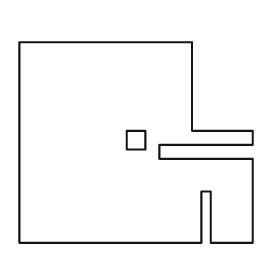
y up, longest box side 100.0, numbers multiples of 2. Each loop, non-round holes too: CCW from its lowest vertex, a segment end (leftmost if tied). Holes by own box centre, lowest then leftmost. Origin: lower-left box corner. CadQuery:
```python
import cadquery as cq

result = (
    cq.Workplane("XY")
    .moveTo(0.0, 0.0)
    .lineTo(78.0, 0.0)
    .lineTo(78.0, 22.0)
    .lineTo(82.0, 22.0)
    .lineTo(82.0, 0.0)
    .lineTo(100.0, 0.0)
    .lineTo(100.0, 36.0)
    .lineTo(60.0, 36.0)
    .lineTo(60.0, 42.0)
    .lineTo(100.0, 42.0)
    .lineTo(100.0, 48.0)
    .lineTo(74.0, 48.0)
    .lineTo(74.0, 86.0)
    .lineTo(0.0, 86.0)
    .close()
    .moveTo(46.0, 40.0)
    .lineTo(54.0, 40.0)
    .lineTo(54.0, 48.0)
    .lineTo(46.0, 48.0)
    .close()
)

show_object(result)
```